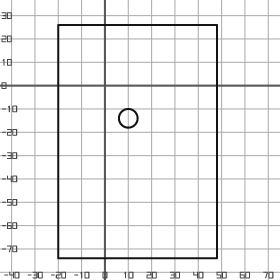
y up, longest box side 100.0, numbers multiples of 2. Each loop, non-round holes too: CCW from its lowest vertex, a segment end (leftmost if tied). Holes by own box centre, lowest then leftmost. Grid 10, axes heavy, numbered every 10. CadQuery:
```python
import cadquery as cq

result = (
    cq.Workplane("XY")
    .moveTo(-20.0, -74.0)
    .lineTo(48.0, -74.0)
    .lineTo(48.0, 26.0)
    .lineTo(-20.0, 26.0)
    .close()
    .moveTo(10.0, -14.0)
    .circle(4.0)
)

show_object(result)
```